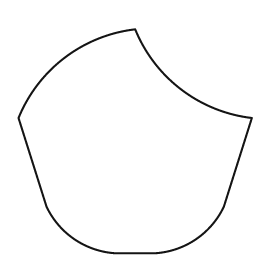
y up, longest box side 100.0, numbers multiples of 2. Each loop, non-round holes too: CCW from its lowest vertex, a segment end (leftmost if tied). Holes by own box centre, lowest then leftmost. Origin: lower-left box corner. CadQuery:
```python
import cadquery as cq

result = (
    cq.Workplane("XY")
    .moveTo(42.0, 0.0)
    .lineTo(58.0, 0.0)
    .threePointArc((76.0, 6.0), (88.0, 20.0))
    .lineTo(100.0, 58.0)
    .threePointArc((70.0, 70.0), (50.0, 96.0))
    .threePointArc((20.0, 84.0), (0.0, 58.0))
    .lineTo(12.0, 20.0)
    .threePointArc((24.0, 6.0), (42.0, 0.0))
    .close()
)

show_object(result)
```